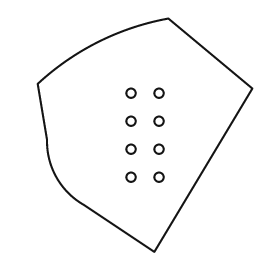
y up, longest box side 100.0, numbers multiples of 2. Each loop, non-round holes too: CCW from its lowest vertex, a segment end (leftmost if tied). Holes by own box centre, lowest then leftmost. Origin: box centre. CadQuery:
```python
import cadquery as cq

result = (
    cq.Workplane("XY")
    .moveTo(4.0, -50.0)
    .lineTo(46.0, 20.0)
    .lineTo(10.0, 50.0)
    .threePointArc((-20.0, 40.0), (-46.0, 22.0))
    .lineTo(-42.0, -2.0)
    .threePointArc((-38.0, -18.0), (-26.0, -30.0))
    .close()
    .moveTo(-6.0, -18.0)
    .circle(2.0)
    .moveTo(6.0, -18.0)
    .circle(2.0)
    .moveTo(-6.0, -6.0)
    .circle(2.0)
    .moveTo(6.0, -6.0)
    .circle(2.0)
    .moveTo(-6.0, 6.0)
    .circle(2.0)
    .moveTo(6.0, 6.0)
    .circle(2.0)
    .moveTo(-6.0, 18.0)
    .circle(2.0)
    .moveTo(6.0, 18.0)
    .circle(2.0)
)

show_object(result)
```